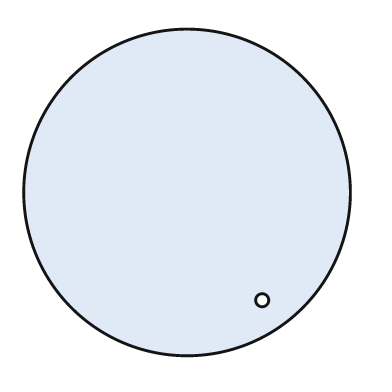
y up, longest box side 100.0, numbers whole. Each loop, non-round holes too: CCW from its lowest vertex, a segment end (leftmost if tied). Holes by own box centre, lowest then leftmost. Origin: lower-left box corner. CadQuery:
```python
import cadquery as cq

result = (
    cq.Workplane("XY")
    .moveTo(50.0, 50.0)
    .circle(50.0)
    .moveTo(73.0, 17.0)
    .circle(2.0)
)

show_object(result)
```